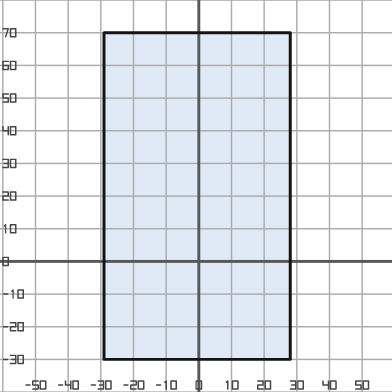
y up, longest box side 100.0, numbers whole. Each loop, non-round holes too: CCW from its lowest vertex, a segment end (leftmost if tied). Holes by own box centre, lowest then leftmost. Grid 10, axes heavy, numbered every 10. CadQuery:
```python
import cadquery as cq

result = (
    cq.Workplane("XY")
    .moveTo(-29.0, -30.0)
    .lineTo(28.0, -30.0)
    .lineTo(28.0, 70.0)
    .lineTo(-29.0, 70.0)
    .close()
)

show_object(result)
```